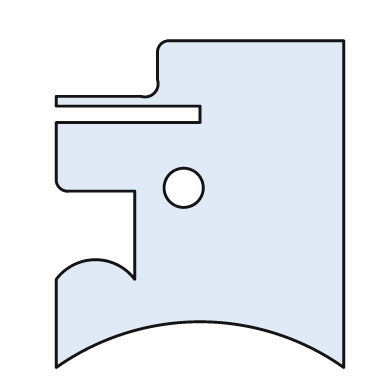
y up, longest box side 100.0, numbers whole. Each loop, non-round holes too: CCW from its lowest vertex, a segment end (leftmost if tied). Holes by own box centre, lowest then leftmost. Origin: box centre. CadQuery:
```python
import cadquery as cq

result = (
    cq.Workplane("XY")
    .moveTo(-44.0, -50.0)
    .threePointArc((0.0, -36.0), (44.0, -50.0))
    .lineTo(44.0, 50.0)
    .lineTo(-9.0, 50.0)
    .threePointArc((-12.0, 49.0), (-13.0, 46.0))
    .lineTo(-13.0, 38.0)
    .threePointArc((-14.0, 34.0), (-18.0, 33.0))
    .lineTo(-44.0, 33.0)
    .lineTo(-44.0, 30.0)
    .lineTo(0.0, 30.0)
    .lineTo(0.0, 25.0)
    .lineTo(-44.0, 25.0)
    .lineTo(-44.0, 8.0)
    .threePointArc((-43.0, 5.0), (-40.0, 4.0))
    .lineTo(-20.0, 4.0)
    .lineTo(-20.0, -23.0)
    .threePointArc((-32.0, -17.0), (-44.0, -23.0))
    .close()
    .moveTo(-5.0, 5.0)
    .circle(6.0)
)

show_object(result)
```